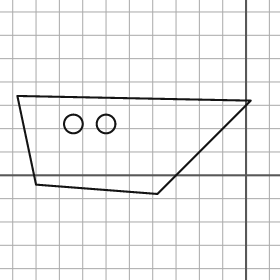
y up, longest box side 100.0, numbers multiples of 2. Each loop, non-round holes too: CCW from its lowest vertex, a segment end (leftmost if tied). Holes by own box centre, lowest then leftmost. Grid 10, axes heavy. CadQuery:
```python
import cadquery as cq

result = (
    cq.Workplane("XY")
    .moveTo(-38.0, -8.0)
    .lineTo(2.0, 32.0)
    .lineTo(-98.0, 34.0)
    .lineTo(-90.0, -4.0)
    .close()
    .moveTo(-74.0, 22.0)
    .circle(4.0)
    .moveTo(-60.0, 22.0)
    .circle(4.0)
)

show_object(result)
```